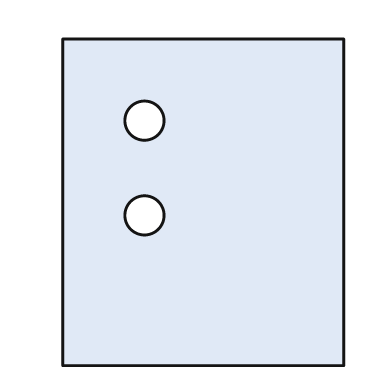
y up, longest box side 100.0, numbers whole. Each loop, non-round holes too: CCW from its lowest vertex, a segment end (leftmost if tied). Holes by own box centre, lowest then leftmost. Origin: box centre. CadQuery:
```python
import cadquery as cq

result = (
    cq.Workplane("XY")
    .moveTo(-43.0, -50.0)
    .lineTo(43.0, -50.0)
    .lineTo(43.0, 50.0)
    .lineTo(-43.0, 50.0)
    .close()
    .moveTo(-18.0, -4.0)
    .circle(6.0)
    .moveTo(-18.0, 25.0)
    .circle(6.0)
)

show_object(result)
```